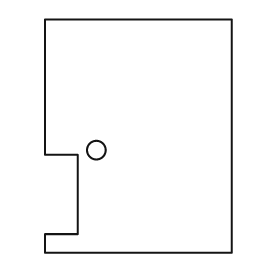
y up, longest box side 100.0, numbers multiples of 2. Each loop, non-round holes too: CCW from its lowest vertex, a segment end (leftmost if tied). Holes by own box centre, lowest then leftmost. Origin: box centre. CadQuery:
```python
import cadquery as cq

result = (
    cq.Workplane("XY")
    .moveTo(-40.0, -50.0)
    .lineTo(40.0, -50.0)
    .lineTo(40.0, 50.0)
    .lineTo(-40.0, 50.0)
    .lineTo(-40.0, -8.0)
    .lineTo(-26.0, -8.0)
    .lineTo(-26.0, -42.0)
    .lineTo(-40.0, -42.0)
    .close()
    .moveTo(-18.0, -6.0)
    .circle(4.0)
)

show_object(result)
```